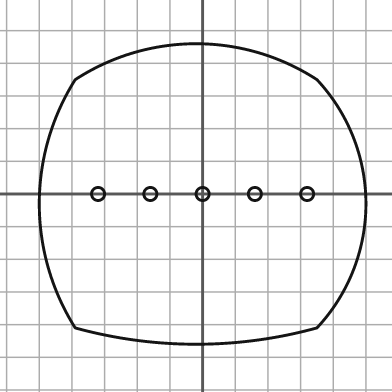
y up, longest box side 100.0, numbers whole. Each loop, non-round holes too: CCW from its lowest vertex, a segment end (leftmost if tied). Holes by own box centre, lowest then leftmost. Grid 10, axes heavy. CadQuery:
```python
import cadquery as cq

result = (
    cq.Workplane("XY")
    .moveTo(-39.0, -41.0)
    .threePointArc((-2.0, -46.0), (35.0, -41.0))
    .threePointArc((50.0, -3.0), (35.0, 35.0))
    .threePointArc((-2.0, 46.0), (-39.0, 35.0))
    .threePointArc((-50.0, -3.0), (-39.0, -41.0))
    .close()
    .moveTo(-32.0, 0.0)
    .circle(2.0)
    .moveTo(-16.0, 0.0)
    .circle(2.0)
    .moveTo(0.0, 0.0)
    .circle(2.0)
    .moveTo(16.0, 0.0)
    .circle(2.0)
    .moveTo(32.0, 0.0)
    .circle(2.0)
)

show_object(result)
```